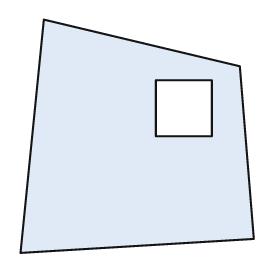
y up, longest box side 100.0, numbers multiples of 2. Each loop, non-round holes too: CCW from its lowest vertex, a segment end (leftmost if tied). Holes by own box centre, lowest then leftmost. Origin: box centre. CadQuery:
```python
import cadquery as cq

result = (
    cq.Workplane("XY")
    .moveTo(-50.0, -50.0)
    .lineTo(50.0, -44.0)
    .lineTo(44.0, 30.0)
    .lineTo(-40.0, 50.0)
    .close()
    .moveTo(8.0, 0.0)
    .lineTo(32.0, 0.0)
    .lineTo(32.0, 24.0)
    .lineTo(8.0, 24.0)
    .close()
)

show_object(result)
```